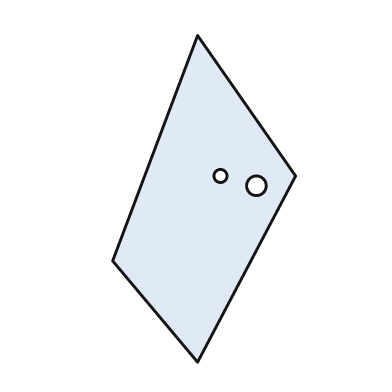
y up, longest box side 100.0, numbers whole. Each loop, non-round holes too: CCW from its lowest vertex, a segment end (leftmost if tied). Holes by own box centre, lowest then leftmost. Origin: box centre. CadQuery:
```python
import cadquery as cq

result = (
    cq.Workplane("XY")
    .moveTo(-2.0, -50.0)
    .lineTo(28.0, 7.0)
    .lineTo(-2.0, 50.0)
    .lineTo(-28.0, -19.0)
    .close()
    .moveTo(16.0, 4.0)
    .circle(3.0)
    .moveTo(5.0, 7.0)
    .circle(2.0)
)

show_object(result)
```